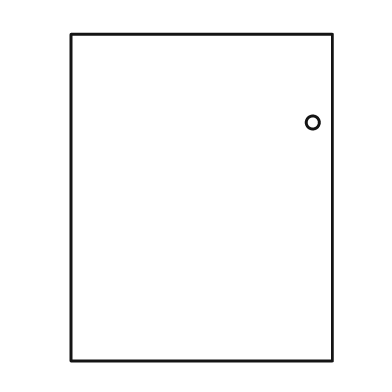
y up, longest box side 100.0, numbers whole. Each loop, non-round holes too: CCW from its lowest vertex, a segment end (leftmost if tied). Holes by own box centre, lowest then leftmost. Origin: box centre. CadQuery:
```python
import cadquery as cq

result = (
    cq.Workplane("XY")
    .moveTo(-40.0, -50.0)
    .lineTo(40.0, -50.0)
    .lineTo(40.0, 50.0)
    .lineTo(-40.0, 50.0)
    .close()
    .moveTo(34.0, 23.0)
    .circle(2.0)
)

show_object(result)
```